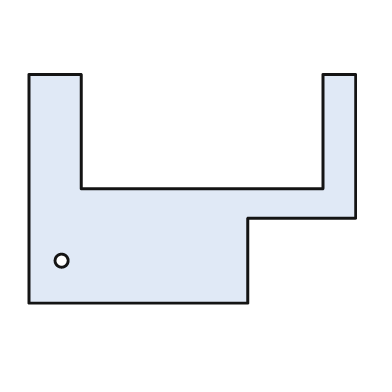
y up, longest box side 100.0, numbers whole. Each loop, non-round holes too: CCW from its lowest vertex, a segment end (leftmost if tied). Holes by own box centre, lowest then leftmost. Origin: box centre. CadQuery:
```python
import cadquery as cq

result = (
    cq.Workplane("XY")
    .moveTo(-50.0, -35.0)
    .lineTo(17.0, -35.0)
    .lineTo(17.0, -9.0)
    .lineTo(50.0, -9.0)
    .lineTo(50.0, 35.0)
    .lineTo(40.0, 35.0)
    .lineTo(40.0, 0.0)
    .lineTo(-34.0, 0.0)
    .lineTo(-34.0, 35.0)
    .lineTo(-50.0, 35.0)
    .close()
    .moveTo(-40.0, -22.0)
    .circle(2.0)
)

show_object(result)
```